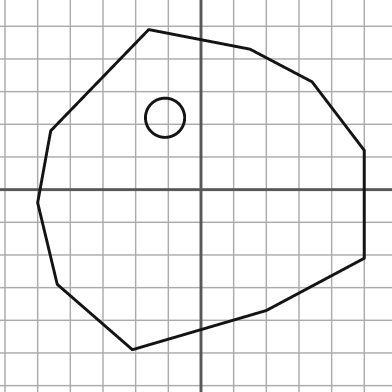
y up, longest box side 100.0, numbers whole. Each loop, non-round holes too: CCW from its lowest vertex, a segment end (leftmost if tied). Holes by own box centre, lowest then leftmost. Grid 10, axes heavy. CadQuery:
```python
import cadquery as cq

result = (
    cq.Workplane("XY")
    .moveTo(-21.0, -49.0)
    .lineTo(20.0, -37.0)
    .lineTo(50.0, -21.0)
    .lineTo(50.0, 12.0)
    .lineTo(34.0, 33.0)
    .lineTo(15.0, 43.0)
    .lineTo(-16.0, 49.0)
    .lineTo(-46.0, 18.0)
    .lineTo(-50.0, -4.0)
    .lineTo(-44.0, -29.0)
    .close()
    .moveTo(-11.0, 22.0)
    .circle(6.0)
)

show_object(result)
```